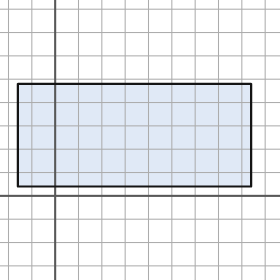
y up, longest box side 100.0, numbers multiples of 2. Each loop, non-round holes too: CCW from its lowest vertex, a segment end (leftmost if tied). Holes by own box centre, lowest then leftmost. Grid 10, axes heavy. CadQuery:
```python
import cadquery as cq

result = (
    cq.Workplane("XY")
    .moveTo(-16.0, 4.0)
    .lineTo(84.0, 4.0)
    .lineTo(84.0, 48.0)
    .lineTo(-16.0, 48.0)
    .close()
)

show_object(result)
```